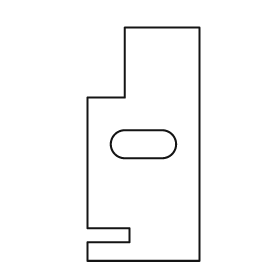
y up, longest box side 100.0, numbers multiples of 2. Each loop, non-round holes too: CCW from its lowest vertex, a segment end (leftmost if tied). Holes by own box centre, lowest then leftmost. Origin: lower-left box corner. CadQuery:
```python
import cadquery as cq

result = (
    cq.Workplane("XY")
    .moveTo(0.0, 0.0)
    .lineTo(48.0, 0.0)
    .lineTo(48.0, 100.0)
    .lineTo(16.0, 100.0)
    .lineTo(16.0, 70.0)
    .lineTo(0.0, 70.0)
    .lineTo(0.0, 14.0)
    .lineTo(18.0, 14.0)
    .lineTo(18.0, 8.0)
    .lineTo(0.0, 8.0)
    .close()
    .moveTo(16.0, 44.0)
    .lineTo(32.0, 44.0)
    .threePointArc((38.0, 50.0), (32.0, 56.0))
    .lineTo(16.0, 56.0)
    .threePointArc((10.0, 50.0), (16.0, 44.0))
    .close()
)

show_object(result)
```